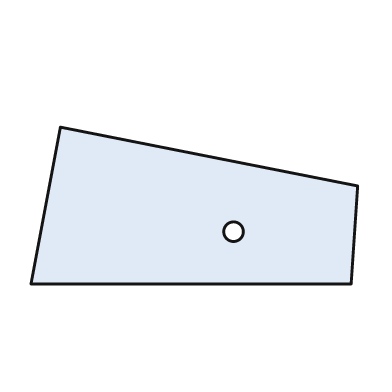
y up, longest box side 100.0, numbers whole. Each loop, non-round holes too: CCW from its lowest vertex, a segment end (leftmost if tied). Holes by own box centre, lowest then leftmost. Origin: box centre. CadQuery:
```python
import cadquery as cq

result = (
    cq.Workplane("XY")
    .moveTo(-50.0, -24.0)
    .lineTo(48.0, -24.0)
    .lineTo(50.0, 6.0)
    .lineTo(-41.0, 24.0)
    .close()
    .moveTo(12.0, -8.0)
    .circle(3.0)
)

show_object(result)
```